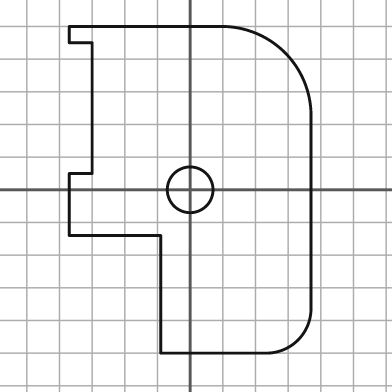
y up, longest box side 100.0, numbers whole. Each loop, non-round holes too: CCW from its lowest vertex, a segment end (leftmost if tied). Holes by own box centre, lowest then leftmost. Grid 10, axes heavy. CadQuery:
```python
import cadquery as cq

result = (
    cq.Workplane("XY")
    .moveTo(-9.0, -50.0)
    .lineTo(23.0, -50.0)
    .threePointArc((33.0, -46.0), (37.0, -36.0))
    .lineTo(37.0, 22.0)
    .threePointArc((29.0, 42.0), (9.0, 50.0))
    .lineTo(-37.0, 50.0)
    .lineTo(-37.0, 45.0)
    .lineTo(-30.0, 45.0)
    .lineTo(-30.0, 5.0)
    .lineTo(-37.0, 5.0)
    .lineTo(-37.0, -14.0)
    .lineTo(-9.0, -14.0)
    .close()
    .moveTo(0.0, 0.0)
    .circle(7.0)
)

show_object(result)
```